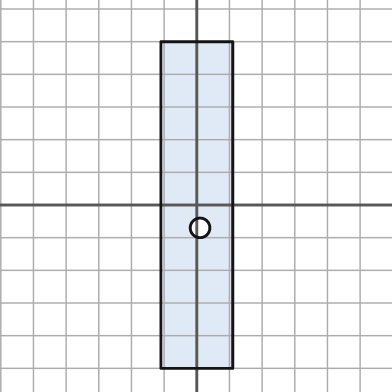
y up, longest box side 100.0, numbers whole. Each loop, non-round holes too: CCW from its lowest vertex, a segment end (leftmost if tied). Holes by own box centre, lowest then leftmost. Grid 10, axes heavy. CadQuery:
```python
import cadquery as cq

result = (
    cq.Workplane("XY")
    .moveTo(-11.0, -50.0)
    .lineTo(11.0, -50.0)
    .lineTo(11.0, 50.0)
    .lineTo(-11.0, 50.0)
    .close()
    .moveTo(1.0, -7.0)
    .circle(3.0)
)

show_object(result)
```